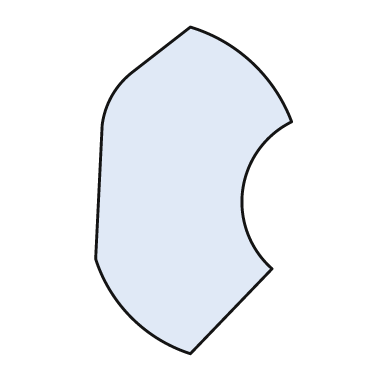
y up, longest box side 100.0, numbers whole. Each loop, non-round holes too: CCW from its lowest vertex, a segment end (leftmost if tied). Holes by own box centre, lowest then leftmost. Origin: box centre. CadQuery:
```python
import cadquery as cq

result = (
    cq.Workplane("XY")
    .moveTo(-1.0, -50.0)
    .lineTo(24.0, -24.0)
    .threePointArc((15.0, 0.0), (30.0, 21.0))
    .threePointArc((18.0, 39.0), (-1.0, 50.0))
    .lineTo(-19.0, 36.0)
    .threePointArc((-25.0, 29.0), (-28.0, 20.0))
    .lineTo(-30.0, -21.0)
    .threePointArc((-19.0, -39.0), (-1.0, -50.0))
    .close()
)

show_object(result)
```